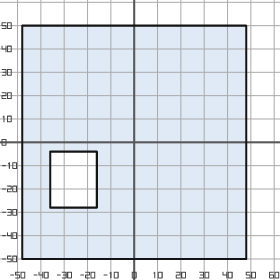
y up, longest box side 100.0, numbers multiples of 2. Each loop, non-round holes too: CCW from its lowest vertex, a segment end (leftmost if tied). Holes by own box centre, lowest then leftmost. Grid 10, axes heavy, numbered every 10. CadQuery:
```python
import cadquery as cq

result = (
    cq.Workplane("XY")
    .moveTo(-48.0, -50.0)
    .lineTo(48.0, -50.0)
    .lineTo(48.0, 50.0)
    .lineTo(-48.0, 50.0)
    .close()
    .moveTo(-36.0, -28.0)
    .lineTo(-16.0, -28.0)
    .lineTo(-16.0, -4.0)
    .lineTo(-36.0, -4.0)
    .close()
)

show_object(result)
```